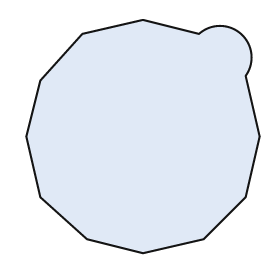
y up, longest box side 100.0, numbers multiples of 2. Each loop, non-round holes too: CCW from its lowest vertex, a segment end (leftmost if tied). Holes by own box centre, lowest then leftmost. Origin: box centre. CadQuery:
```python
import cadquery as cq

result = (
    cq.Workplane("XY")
    .moveTo(0.0, -50.0)
    .lineTo(26.0, -44.0)
    .lineTo(44.0, -26.0)
    .lineTo(50.0, 0.0)
    .lineTo(44.0, 26.0)
    .threePointArc((42.0, 44.0), (24.0, 44.0))
    .lineTo(0.0, 50.0)
    .lineTo(-26.0, 44.0)
    .lineTo(-44.0, 24.0)
    .lineTo(-50.0, 0.0)
    .lineTo(-44.0, -26.0)
    .lineTo(-24.0, -44.0)
    .close()
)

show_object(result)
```